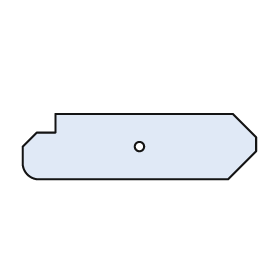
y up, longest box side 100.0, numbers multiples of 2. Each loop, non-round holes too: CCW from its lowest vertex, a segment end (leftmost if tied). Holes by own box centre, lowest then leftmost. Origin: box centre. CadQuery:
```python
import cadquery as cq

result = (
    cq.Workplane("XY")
    .moveTo(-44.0, -14.0)
    .lineTo(38.0, -14.0)
    .lineTo(50.0, -2.0)
    .lineTo(50.0, 4.0)
    .lineTo(40.0, 14.0)
    .lineTo(-36.0, 14.0)
    .lineTo(-36.0, 6.0)
    .lineTo(-44.0, 6.0)
    .lineTo(-50.0, 0.0)
    .lineTo(-50.0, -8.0)
    .threePointArc((-48.0, -12.0), (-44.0, -14.0))
    .close()
    .moveTo(0.0, 0.0)
    .circle(2.0)
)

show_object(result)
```